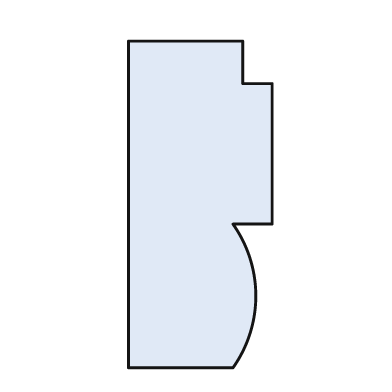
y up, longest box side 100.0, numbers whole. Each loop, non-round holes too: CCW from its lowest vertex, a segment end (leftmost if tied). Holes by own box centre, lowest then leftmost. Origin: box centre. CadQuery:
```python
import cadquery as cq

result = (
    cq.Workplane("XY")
    .moveTo(-22.0, -50.0)
    .lineTo(10.0, -50.0)
    .threePointArc((17.0, -28.0), (10.0, -6.0))
    .lineTo(22.0, -6.0)
    .lineTo(22.0, 37.0)
    .lineTo(13.0, 37.0)
    .lineTo(13.0, 50.0)
    .lineTo(-22.0, 50.0)
    .close()
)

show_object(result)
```